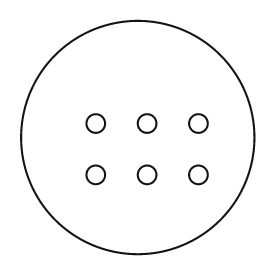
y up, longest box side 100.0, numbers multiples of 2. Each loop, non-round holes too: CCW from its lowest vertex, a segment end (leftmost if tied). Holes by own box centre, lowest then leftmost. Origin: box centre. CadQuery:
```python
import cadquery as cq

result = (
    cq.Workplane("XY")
    .moveTo(0.0, 0.0)
    .circle(50.0)
    .moveTo(-18.0, -16.0)
    .circle(4.0)
    .moveTo(4.0, -16.0)
    .circle(4.0)
    .moveTo(26.0, -16.0)
    .circle(4.0)
    .moveTo(-18.0, 6.0)
    .circle(4.0)
    .moveTo(4.0, 6.0)
    .circle(4.0)
    .moveTo(26.0, 6.0)
    .circle(4.0)
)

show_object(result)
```